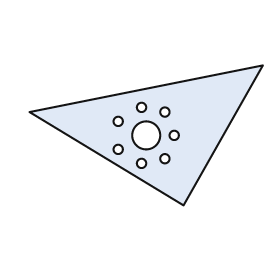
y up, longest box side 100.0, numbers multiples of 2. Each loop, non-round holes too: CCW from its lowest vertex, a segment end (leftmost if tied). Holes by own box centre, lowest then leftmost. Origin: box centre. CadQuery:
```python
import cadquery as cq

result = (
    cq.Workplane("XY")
    .moveTo(16.0, -30.0)
    .lineTo(50.0, 30.0)
    .lineTo(-50.0, 10.0)
    .close()
    .moveTo(-2.0, -12.0)
    .circle(2.0)
    .moveTo(8.0, -10.0)
    .circle(2.0)
    .moveTo(-12.0, -6.0)
    .circle(2.0)
    .moveTo(0.0, 0.0)
    .circle(6.0)
    .moveTo(12.0, 0.0)
    .circle(2.0)
    .moveTo(-12.0, 6.0)
    .circle(2.0)
    .moveTo(8.0, 10.0)
    .circle(2.0)
    .moveTo(-2.0, 12.0)
    .circle(2.0)
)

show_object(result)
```